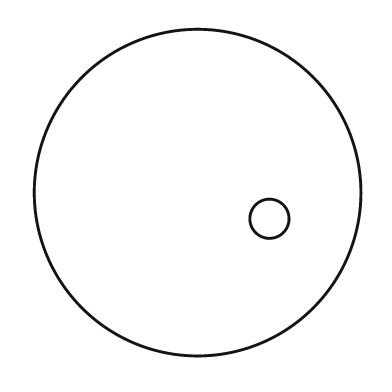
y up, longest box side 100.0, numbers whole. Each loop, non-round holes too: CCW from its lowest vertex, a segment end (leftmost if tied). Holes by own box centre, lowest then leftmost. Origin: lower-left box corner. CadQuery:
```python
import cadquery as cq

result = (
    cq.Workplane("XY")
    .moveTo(50.0, 50.0)
    .circle(50.0)
    .moveTo(72.0, 42.0)
    .circle(6.0)
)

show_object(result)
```